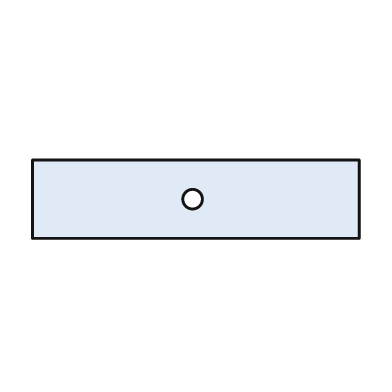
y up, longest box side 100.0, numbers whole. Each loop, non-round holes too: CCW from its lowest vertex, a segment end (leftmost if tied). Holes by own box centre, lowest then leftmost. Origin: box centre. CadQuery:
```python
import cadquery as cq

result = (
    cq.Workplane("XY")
    .moveTo(-50.0, -12.0)
    .lineTo(50.0, -12.0)
    .lineTo(50.0, 12.0)
    .lineTo(-50.0, 12.0)
    .close()
    .moveTo(-1.0, 0.0)
    .circle(3.0)
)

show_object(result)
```